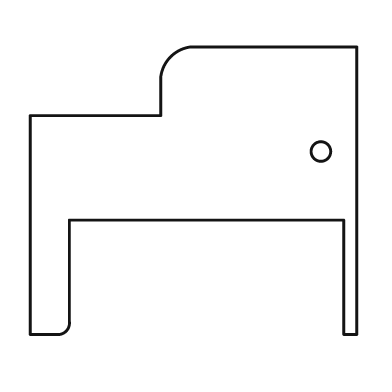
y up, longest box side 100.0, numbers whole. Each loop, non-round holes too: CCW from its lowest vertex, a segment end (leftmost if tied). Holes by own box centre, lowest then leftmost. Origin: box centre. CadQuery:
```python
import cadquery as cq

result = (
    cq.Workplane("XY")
    .moveTo(-50.0, -44.0)
    .lineTo(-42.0, -44.0)
    .threePointArc((-39.0, -43.0), (-38.0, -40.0))
    .lineTo(-38.0, -9.0)
    .lineTo(46.0, -9.0)
    .lineTo(46.0, -44.0)
    .lineTo(50.0, -44.0)
    .lineTo(50.0, 44.0)
    .lineTo(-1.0, 44.0)
    .threePointArc((-7.0, 41.0), (-10.0, 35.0))
    .lineTo(-10.0, 23.0)
    .lineTo(-50.0, 23.0)
    .close()
    .moveTo(39.0, 12.0)
    .circle(3.0)
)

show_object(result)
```